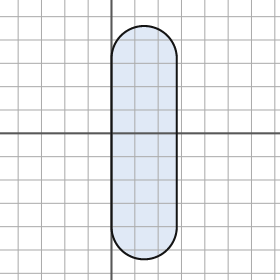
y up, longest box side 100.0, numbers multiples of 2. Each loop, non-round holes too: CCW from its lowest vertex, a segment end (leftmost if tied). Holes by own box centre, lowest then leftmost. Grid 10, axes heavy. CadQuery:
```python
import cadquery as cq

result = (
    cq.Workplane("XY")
    .moveTo(0.0, -40.0)
    .threePointArc((14.0, -54.0), (28.0, -40.0))
    .lineTo(28.0, 32.0)
    .threePointArc((14.0, 46.0), (0.0, 32.0))
    .close()
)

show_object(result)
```